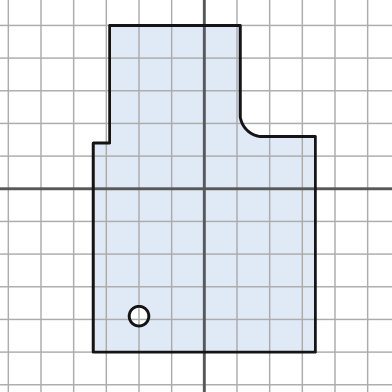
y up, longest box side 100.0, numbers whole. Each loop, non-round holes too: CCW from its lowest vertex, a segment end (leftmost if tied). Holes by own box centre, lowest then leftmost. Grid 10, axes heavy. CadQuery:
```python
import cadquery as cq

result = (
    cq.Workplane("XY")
    .moveTo(-34.0, -50.0)
    .lineTo(34.0, -50.0)
    .lineTo(34.0, 16.0)
    .lineTo(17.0, 16.0)
    .threePointArc((13.0, 18.0), (11.0, 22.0))
    .lineTo(11.0, 50.0)
    .lineTo(-29.0, 50.0)
    .lineTo(-29.0, 14.0)
    .lineTo(-34.0, 14.0)
    .close()
    .moveTo(-20.0, -39.0)
    .circle(3.0)
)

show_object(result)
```